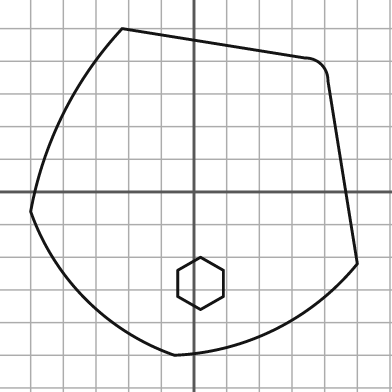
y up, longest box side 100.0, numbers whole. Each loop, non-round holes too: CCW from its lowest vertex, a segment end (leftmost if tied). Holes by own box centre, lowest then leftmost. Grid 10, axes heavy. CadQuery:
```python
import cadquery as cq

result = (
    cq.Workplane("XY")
    .moveTo(-6.0, -50.0)
    .threePointArc((25.0, -42.0), (50.0, -22.0))
    .lineTo(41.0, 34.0)
    .threePointArc((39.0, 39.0), (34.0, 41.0))
    .lineTo(-22.0, 50.0)
    .threePointArc((-40.0, 24.0), (-50.0, -6.0))
    .threePointArc((-33.0, -33.0), (-6.0, -50.0))
    .close()
    .moveTo(2.0, -36.0)
    .lineTo(9.0, -32.0)
    .lineTo(9.0, -24.0)
    .lineTo(2.0, -20.0)
    .lineTo(-5.0, -24.0)
    .lineTo(-5.0, -32.0)
    .close()
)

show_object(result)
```